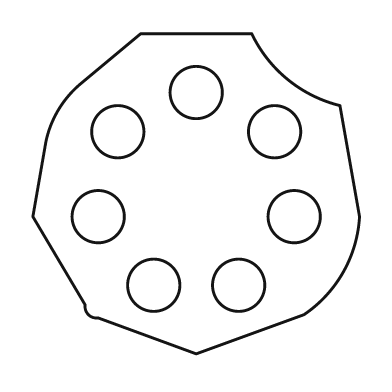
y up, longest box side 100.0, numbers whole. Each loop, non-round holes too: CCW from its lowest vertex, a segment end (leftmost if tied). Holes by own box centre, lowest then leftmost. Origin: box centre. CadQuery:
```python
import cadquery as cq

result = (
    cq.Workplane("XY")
    .moveTo(0.0, -49.0)
    .lineTo(33.0, -37.0)
    .threePointArc((45.0, -24.0), (50.0, -7.0))
    .lineTo(44.0, 27.0)
    .threePointArc((28.0, 35.0), (17.0, 49.0))
    .lineTo(-17.0, 49.0)
    .lineTo(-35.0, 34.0)
    .threePointArc((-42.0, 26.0), (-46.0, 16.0))
    .lineTo(-50.0, -7.0)
    .lineTo(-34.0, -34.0)
    .threePointArc((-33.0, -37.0), (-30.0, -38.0))
    .close()
    .moveTo(-13.0, -28.0)
    .circle(8.0)
    .moveTo(13.0, -28.0)
    .circle(8.0)
    .moveTo(-30.0, -7.0)
    .circle(8.0)
    .moveTo(30.0, -7.0)
    .circle(8.0)
    .moveTo(-24.0, 19.0)
    .circle(8.0)
    .moveTo(24.0, 19.0)
    .circle(8.0)
    .moveTo(0.0, 31.0)
    .circle(8.0)
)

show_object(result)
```